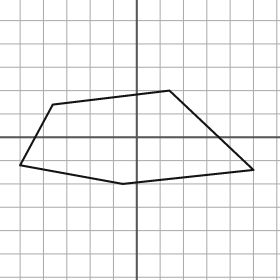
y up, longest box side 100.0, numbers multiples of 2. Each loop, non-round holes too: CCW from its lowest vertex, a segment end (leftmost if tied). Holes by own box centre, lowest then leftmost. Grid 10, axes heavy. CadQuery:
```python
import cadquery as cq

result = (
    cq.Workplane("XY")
    .moveTo(-6.0, -20.0)
    .lineTo(50.0, -14.0)
    .lineTo(14.0, 20.0)
    .lineTo(-36.0, 14.0)
    .lineTo(-50.0, -12.0)
    .close()
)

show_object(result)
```